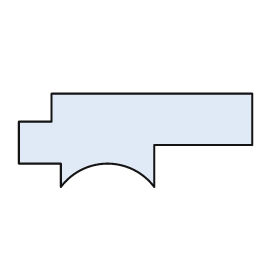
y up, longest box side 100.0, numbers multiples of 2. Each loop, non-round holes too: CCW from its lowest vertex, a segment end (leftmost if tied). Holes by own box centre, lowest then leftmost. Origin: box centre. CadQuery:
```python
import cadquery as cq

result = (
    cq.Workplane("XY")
    .moveTo(-32.0, -20.0)
    .threePointArc((-12.0, -10.0), (8.0, -20.0))
    .lineTo(8.0, -2.0)
    .lineTo(50.0, -2.0)
    .lineTo(50.0, 20.0)
    .lineTo(-36.0, 20.0)
    .lineTo(-36.0, 8.0)
    .lineTo(-50.0, 8.0)
    .lineTo(-50.0, -10.0)
    .lineTo(-32.0, -10.0)
    .close()
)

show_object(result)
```